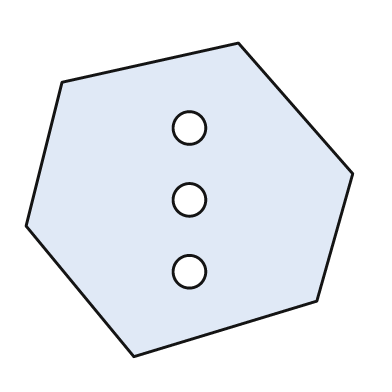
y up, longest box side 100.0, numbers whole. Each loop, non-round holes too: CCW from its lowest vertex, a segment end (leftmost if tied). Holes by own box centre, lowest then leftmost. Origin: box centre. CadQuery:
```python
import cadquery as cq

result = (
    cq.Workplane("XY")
    .moveTo(-17.0, -48.0)
    .lineTo(39.0, -31.0)
    .lineTo(50.0, 8.0)
    .lineTo(15.0, 48.0)
    .lineTo(-39.0, 36.0)
    .lineTo(-50.0, -8.0)
    .close()
    .moveTo(0.0, -22.0)
    .circle(5.0)
    .moveTo(0.0, 0.0)
    .circle(5.0)
    .moveTo(0.0, 22.0)
    .circle(5.0)
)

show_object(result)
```